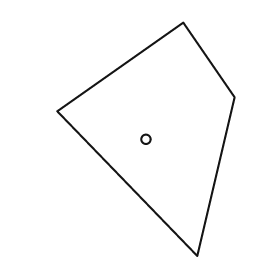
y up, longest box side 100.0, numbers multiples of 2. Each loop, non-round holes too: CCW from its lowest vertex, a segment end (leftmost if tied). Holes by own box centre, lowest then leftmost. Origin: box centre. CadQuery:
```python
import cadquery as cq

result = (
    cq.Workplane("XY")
    .moveTo(22.0, -50.0)
    .lineTo(38.0, 18.0)
    .lineTo(16.0, 50.0)
    .lineTo(-38.0, 12.0)
    .close()
    .moveTo(0.0, 0.0)
    .circle(2.0)
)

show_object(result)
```